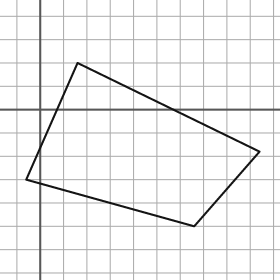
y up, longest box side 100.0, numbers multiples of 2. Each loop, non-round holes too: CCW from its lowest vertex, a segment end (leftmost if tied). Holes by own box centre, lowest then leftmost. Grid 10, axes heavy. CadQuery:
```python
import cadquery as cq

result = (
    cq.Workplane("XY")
    .moveTo(66.0, -50.0)
    .lineTo(94.0, -18.0)
    .lineTo(16.0, 20.0)
    .lineTo(-6.0, -30.0)
    .close()
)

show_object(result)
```